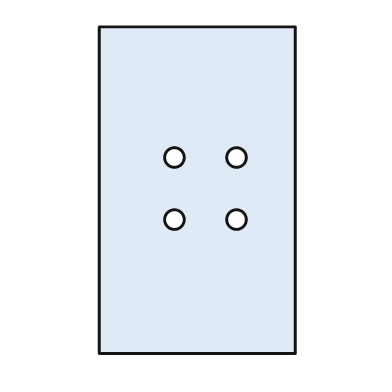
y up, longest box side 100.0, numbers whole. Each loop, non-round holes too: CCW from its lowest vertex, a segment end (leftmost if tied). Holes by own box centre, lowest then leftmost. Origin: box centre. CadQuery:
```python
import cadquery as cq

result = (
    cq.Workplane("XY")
    .moveTo(-30.0, -50.0)
    .lineTo(30.0, -50.0)
    .lineTo(30.0, 50.0)
    .lineTo(-30.0, 50.0)
    .close()
    .moveTo(-7.0, -9.0)
    .circle(3.0)
    .moveTo(12.0, -9.0)
    .circle(3.0)
    .moveTo(-7.0, 10.0)
    .circle(3.0)
    .moveTo(12.0, 10.0)
    .circle(3.0)
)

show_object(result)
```